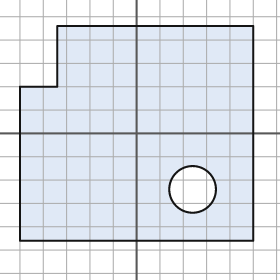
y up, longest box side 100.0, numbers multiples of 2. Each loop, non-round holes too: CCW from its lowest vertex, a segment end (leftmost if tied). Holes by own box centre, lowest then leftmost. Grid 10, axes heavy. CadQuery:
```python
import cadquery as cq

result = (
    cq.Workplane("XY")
    .moveTo(-50.0, -46.0)
    .lineTo(50.0, -46.0)
    .lineTo(50.0, 46.0)
    .lineTo(-34.0, 46.0)
    .lineTo(-34.0, 20.0)
    .lineTo(-50.0, 20.0)
    .close()
    .moveTo(24.0, -24.0)
    .circle(10.0)
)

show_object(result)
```